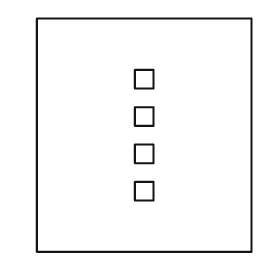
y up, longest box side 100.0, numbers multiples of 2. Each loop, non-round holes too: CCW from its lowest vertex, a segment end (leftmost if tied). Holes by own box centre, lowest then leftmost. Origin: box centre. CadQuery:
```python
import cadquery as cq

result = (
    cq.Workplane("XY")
    .moveTo(-46.0, -50.0)
    .lineTo(46.0, -50.0)
    .lineTo(46.0, 50.0)
    .lineTo(-46.0, 50.0)
    .close()
    .moveTo(-4.0, -28.0)
    .lineTo(4.0, -28.0)
    .lineTo(4.0, -20.0)
    .lineTo(-4.0, -20.0)
    .close()
    .moveTo(-4.0, -12.0)
    .lineTo(4.0, -12.0)
    .lineTo(4.0, -4.0)
    .lineTo(-4.0, -4.0)
    .close()
    .moveTo(-4.0, 4.0)
    .lineTo(4.0, 4.0)
    .lineTo(4.0, 12.0)
    .lineTo(-4.0, 12.0)
    .close()
    .moveTo(-4.0, 20.0)
    .lineTo(4.0, 20.0)
    .lineTo(4.0, 28.0)
    .lineTo(-4.0, 28.0)
    .close()
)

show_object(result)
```